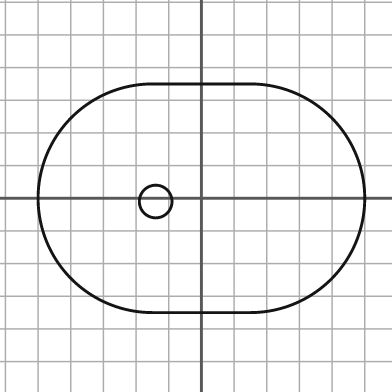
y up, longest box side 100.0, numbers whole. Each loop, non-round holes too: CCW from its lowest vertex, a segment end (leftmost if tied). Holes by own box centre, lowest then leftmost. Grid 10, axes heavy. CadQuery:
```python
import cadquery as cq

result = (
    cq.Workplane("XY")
    .moveTo(-15.0, -35.0)
    .lineTo(15.0, -35.0)
    .threePointArc((50.0, 0.0), (15.0, 35.0))
    .lineTo(-15.0, 35.0)
    .threePointArc((-50.0, 0.0), (-15.0, -35.0))
    .close()
    .moveTo(-14.0, -1.0)
    .circle(5.0)
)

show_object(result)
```